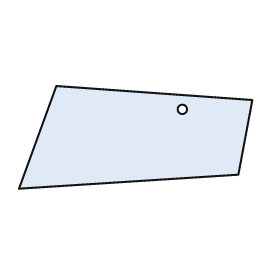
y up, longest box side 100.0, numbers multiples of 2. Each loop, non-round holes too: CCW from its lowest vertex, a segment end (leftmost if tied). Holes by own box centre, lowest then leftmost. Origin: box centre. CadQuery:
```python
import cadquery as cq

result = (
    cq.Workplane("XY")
    .moveTo(-50.0, -22.0)
    .lineTo(44.0, -16.0)
    .lineTo(50.0, 16.0)
    .lineTo(-34.0, 22.0)
    .close()
    .moveTo(20.0, 12.0)
    .circle(2.0)
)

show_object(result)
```